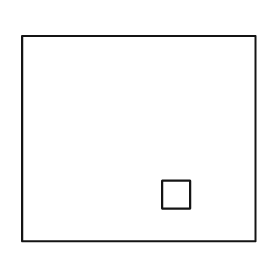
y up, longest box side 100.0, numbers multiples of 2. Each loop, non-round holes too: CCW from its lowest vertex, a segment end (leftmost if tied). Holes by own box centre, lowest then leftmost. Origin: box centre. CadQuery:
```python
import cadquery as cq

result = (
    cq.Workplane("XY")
    .moveTo(-50.0, -44.0)
    .lineTo(50.0, -44.0)
    .lineTo(50.0, 44.0)
    .lineTo(-50.0, 44.0)
    .close()
    .moveTo(10.0, -30.0)
    .lineTo(22.0, -30.0)
    .lineTo(22.0, -18.0)
    .lineTo(10.0, -18.0)
    .close()
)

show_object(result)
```